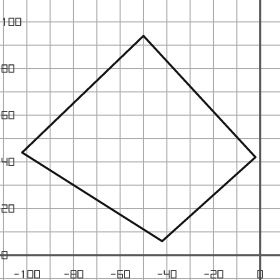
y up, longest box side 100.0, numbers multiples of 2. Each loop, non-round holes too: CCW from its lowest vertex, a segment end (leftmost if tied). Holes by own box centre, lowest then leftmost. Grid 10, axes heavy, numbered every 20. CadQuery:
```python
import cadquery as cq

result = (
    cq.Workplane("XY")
    .moveTo(-42.0, 6.0)
    .lineTo(-2.0, 42.0)
    .lineTo(-50.0, 94.0)
    .lineTo(-102.0, 44.0)
    .close()
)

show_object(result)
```